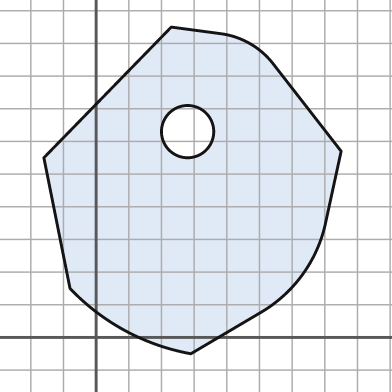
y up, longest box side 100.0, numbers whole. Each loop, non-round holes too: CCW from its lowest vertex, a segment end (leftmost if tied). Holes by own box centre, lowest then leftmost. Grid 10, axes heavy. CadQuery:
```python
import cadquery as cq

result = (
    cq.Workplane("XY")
    .moveTo(29.0, -5.0)
    .lineTo(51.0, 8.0)
    .threePointArc((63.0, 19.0), (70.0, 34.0))
    .lineTo(75.0, 57.0)
    .lineTo(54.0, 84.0)
    .threePointArc((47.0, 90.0), (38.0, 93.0))
    .lineTo(23.0, 95.0)
    .lineTo(-16.0, 55.0)
    .lineTo(-8.0, 15.0)
    .threePointArc((9.0, 2.0), (29.0, -5.0))
    .close()
    .moveTo(28.0, 63.0)
    .circle(8.0)
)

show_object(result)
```